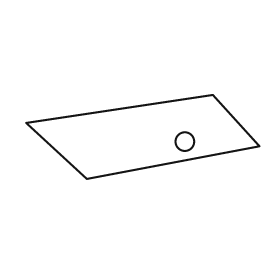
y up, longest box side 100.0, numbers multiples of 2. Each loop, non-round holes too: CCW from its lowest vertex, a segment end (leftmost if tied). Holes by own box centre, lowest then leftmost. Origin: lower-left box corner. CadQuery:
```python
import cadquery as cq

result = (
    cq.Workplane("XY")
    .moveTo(26.0, 0.0)
    .lineTo(100.0, 14.0)
    .lineTo(80.0, 36.0)
    .lineTo(0.0, 24.0)
    .close()
    .moveTo(68.0, 16.0)
    .circle(4.0)
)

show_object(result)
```